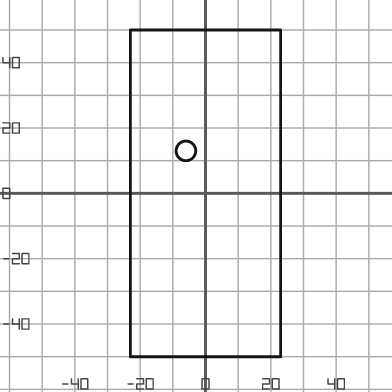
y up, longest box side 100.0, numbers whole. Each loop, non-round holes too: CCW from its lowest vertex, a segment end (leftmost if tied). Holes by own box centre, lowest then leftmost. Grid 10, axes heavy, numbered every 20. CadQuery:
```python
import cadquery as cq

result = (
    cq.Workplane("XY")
    .moveTo(-23.0, -50.0)
    .lineTo(23.0, -50.0)
    .lineTo(23.0, 50.0)
    .lineTo(-23.0, 50.0)
    .close()
    .moveTo(-6.0, 13.0)
    .circle(3.0)
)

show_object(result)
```